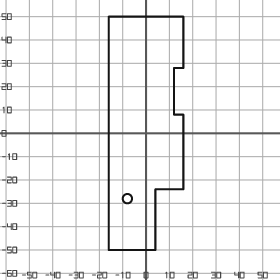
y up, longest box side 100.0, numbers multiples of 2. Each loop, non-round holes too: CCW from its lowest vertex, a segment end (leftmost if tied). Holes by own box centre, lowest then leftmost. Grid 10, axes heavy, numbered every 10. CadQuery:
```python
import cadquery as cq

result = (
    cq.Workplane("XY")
    .moveTo(-16.0, -50.0)
    .lineTo(4.0, -50.0)
    .lineTo(4.0, -24.0)
    .lineTo(16.0, -24.0)
    .lineTo(16.0, 8.0)
    .lineTo(12.0, 8.0)
    .lineTo(12.0, 28.0)
    .lineTo(16.0, 28.0)
    .lineTo(16.0, 50.0)
    .lineTo(-16.0, 50.0)
    .close()
    .moveTo(-8.0, -28.0)
    .circle(2.0)
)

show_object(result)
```